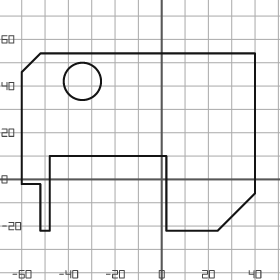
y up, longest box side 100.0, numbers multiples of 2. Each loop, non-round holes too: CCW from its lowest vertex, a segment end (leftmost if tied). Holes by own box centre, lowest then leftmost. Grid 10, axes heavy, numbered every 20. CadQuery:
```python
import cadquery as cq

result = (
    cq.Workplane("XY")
    .moveTo(-52.0, -22.0)
    .lineTo(-48.0, -22.0)
    .lineTo(-48.0, 10.0)
    .lineTo(2.0, 10.0)
    .lineTo(2.0, -22.0)
    .lineTo(24.0, -22.0)
    .lineTo(40.0, -6.0)
    .lineTo(40.0, 54.0)
    .lineTo(-52.0, 54.0)
    .lineTo(-60.0, 46.0)
    .lineTo(-60.0, -2.0)
    .lineTo(-52.0, -2.0)
    .close()
    .moveTo(-34.0, 42.0)
    .circle(8.0)
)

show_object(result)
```